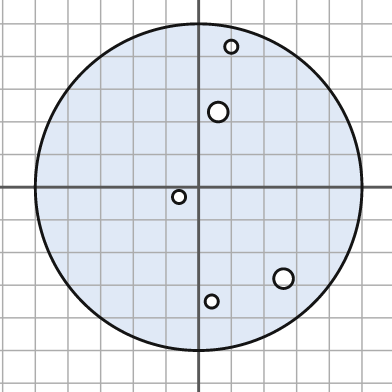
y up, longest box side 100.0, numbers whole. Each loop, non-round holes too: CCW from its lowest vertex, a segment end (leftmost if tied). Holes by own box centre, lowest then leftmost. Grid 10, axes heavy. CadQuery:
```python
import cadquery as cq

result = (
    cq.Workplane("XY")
    .moveTo(0.0, 0.0)
    .circle(50.0)
    .moveTo(4.0, -35.0)
    .circle(2.0)
    .moveTo(26.0, -28.0)
    .circle(3.0)
    .moveTo(-6.0, -3.0)
    .circle(2.0)
    .moveTo(6.0, 23.0)
    .circle(3.0)
    .moveTo(10.0, 43.0)
    .circle(2.0)
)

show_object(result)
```